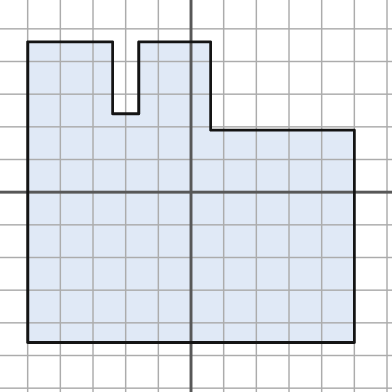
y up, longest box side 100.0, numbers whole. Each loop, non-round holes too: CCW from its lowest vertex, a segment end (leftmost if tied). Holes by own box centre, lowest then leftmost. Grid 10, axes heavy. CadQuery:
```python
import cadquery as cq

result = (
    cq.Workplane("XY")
    .moveTo(-50.0, -46.0)
    .lineTo(50.0, -46.0)
    .lineTo(50.0, 19.0)
    .lineTo(6.0, 19.0)
    .lineTo(6.0, 46.0)
    .lineTo(-16.0, 46.0)
    .lineTo(-16.0, 24.0)
    .lineTo(-24.0, 24.0)
    .lineTo(-24.0, 46.0)
    .lineTo(-50.0, 46.0)
    .close()
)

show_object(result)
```